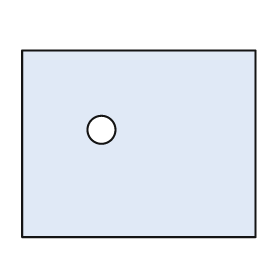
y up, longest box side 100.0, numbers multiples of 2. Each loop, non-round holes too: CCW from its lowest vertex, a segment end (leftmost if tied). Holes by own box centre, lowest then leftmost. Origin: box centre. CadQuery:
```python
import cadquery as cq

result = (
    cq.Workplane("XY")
    .moveTo(-50.0, -40.0)
    .lineTo(50.0, -40.0)
    .lineTo(50.0, 40.0)
    .lineTo(-50.0, 40.0)
    .close()
    .moveTo(-16.0, 6.0)
    .circle(6.0)
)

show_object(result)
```